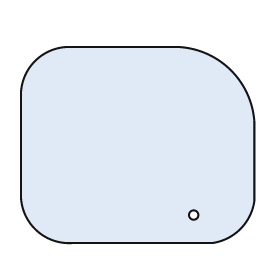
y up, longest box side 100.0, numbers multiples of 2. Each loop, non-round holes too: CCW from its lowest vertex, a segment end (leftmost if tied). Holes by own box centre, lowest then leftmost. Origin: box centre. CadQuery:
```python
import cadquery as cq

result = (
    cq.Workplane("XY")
    .moveTo(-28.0, -42.0)
    .lineTo(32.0, -42.0)
    .threePointArc((44.0, -36.0), (50.0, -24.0))
    .lineTo(50.0, 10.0)
    .threePointArc((40.0, 32.0), (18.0, 42.0))
    .lineTo(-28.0, 42.0)
    .threePointArc((-44.0, 36.0), (-50.0, 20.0))
    .lineTo(-50.0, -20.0)
    .threePointArc((-44.0, -36.0), (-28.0, -42.0))
    .close()
    .moveTo(24.0, -30.0)
    .circle(2.0)
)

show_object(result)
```